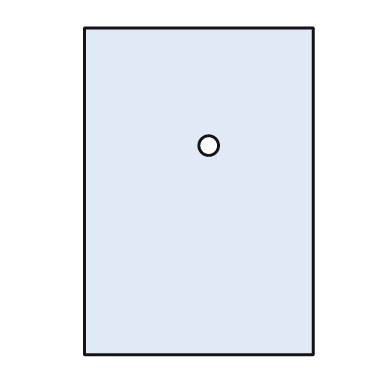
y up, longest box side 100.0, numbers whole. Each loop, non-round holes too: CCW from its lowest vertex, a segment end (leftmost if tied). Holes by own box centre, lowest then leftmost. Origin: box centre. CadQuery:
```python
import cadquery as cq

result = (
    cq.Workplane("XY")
    .moveTo(-35.0, -50.0)
    .lineTo(35.0, -50.0)
    .lineTo(35.0, 50.0)
    .lineTo(-35.0, 50.0)
    .close()
    .moveTo(3.0, 14.0)
    .circle(3.0)
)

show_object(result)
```